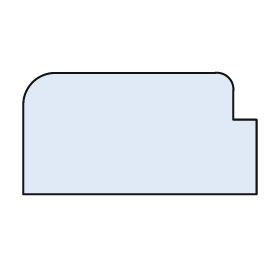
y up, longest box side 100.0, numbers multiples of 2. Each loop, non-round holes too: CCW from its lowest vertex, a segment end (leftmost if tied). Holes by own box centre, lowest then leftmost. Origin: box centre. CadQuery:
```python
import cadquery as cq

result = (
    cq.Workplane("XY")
    .moveTo(-50.0, -26.0)
    .lineTo(50.0, -26.0)
    .lineTo(50.0, 6.0)
    .lineTo(40.0, 6.0)
    .lineTo(40.0, 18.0)
    .threePointArc((38.0, 24.0), (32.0, 26.0))
    .lineTo(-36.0, 26.0)
    .threePointArc((-46.0, 22.0), (-50.0, 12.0))
    .close()
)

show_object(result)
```